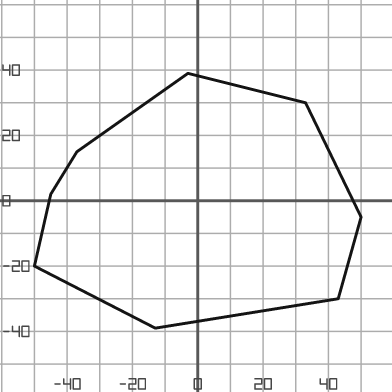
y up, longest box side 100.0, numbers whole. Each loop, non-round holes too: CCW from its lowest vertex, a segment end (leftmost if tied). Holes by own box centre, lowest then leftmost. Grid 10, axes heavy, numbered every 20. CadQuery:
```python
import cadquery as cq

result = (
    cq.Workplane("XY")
    .moveTo(-13.0, -39.0)
    .lineTo(43.0, -30.0)
    .lineTo(50.0, -5.0)
    .lineTo(33.0, 30.0)
    .lineTo(-3.0, 39.0)
    .lineTo(-37.0, 15.0)
    .lineTo(-45.0, 2.0)
    .lineTo(-50.0, -20.0)
    .close()
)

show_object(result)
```